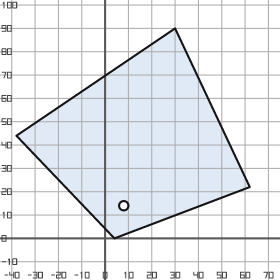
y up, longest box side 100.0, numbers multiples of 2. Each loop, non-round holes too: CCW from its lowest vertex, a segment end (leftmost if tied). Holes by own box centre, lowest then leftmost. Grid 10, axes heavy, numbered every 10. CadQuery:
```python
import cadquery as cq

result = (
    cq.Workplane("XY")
    .moveTo(4.0, 0.0)
    .lineTo(62.0, 22.0)
    .lineTo(30.0, 90.0)
    .lineTo(-38.0, 44.0)
    .close()
    .moveTo(8.0, 14.0)
    .circle(2.0)
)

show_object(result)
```